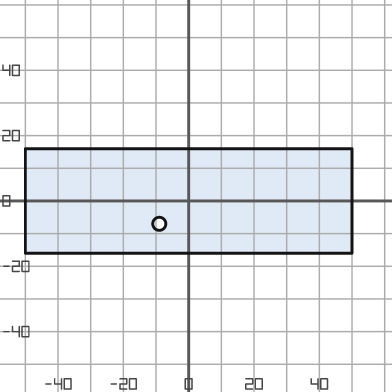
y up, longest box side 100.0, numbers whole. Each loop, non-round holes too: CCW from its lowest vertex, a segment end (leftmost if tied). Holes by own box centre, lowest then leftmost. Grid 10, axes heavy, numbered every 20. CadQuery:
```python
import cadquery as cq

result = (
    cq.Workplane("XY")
    .moveTo(-50.0, -16.0)
    .lineTo(50.0, -16.0)
    .lineTo(50.0, 16.0)
    .lineTo(-50.0, 16.0)
    .close()
    .moveTo(-9.0, -7.0)
    .circle(2.0)
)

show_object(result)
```